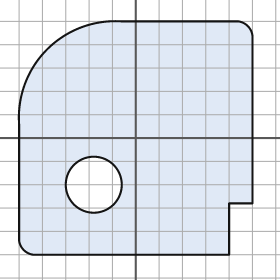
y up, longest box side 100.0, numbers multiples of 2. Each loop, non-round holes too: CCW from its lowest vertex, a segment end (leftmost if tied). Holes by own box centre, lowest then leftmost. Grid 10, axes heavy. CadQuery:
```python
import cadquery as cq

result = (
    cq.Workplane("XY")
    .moveTo(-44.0, -50.0)
    .lineTo(40.0, -50.0)
    .lineTo(40.0, -28.0)
    .lineTo(50.0, -28.0)
    .lineTo(50.0, 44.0)
    .threePointArc((48.0, 48.0), (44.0, 50.0))
    .lineTo(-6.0, 50.0)
    .threePointArc((-38.0, 38.0), (-50.0, 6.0))
    .lineTo(-50.0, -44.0)
    .threePointArc((-48.0, -48.0), (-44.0, -50.0))
    .close()
    .moveTo(-18.0, -20.0)
    .circle(12.0)
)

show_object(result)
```